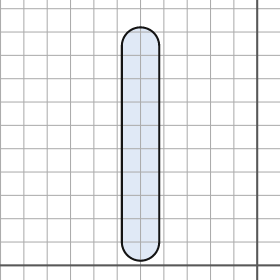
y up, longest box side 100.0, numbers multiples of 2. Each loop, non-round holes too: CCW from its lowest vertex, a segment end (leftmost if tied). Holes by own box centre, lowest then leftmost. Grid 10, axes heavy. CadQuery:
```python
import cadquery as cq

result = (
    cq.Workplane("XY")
    .moveTo(-58.0, 10.0)
    .threePointArc((-50.0, 2.0), (-42.0, 10.0))
    .lineTo(-42.0, 94.0)
    .threePointArc((-50.0, 102.0), (-58.0, 94.0))
    .close()
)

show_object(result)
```